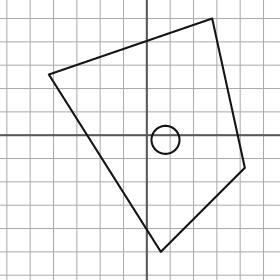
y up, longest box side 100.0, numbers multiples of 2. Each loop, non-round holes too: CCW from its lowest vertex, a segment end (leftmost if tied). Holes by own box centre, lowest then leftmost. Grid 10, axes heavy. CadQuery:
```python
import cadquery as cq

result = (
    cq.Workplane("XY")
    .moveTo(6.0, -50.0)
    .lineTo(42.0, -14.0)
    .lineTo(28.0, 50.0)
    .lineTo(-42.0, 26.0)
    .close()
    .moveTo(8.0, -2.0)
    .circle(6.0)
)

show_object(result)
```